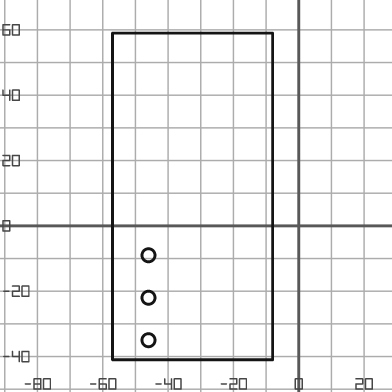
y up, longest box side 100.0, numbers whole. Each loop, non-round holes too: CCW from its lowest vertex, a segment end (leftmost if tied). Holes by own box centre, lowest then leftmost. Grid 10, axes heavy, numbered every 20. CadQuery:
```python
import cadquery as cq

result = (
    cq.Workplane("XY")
    .moveTo(-57.0, -41.0)
    .lineTo(-8.0, -41.0)
    .lineTo(-8.0, 59.0)
    .lineTo(-57.0, 59.0)
    .close()
    .moveTo(-46.0, -35.0)
    .circle(2.0)
    .moveTo(-46.0, -22.0)
    .circle(2.0)
    .moveTo(-46.0, -9.0)
    .circle(2.0)
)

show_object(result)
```